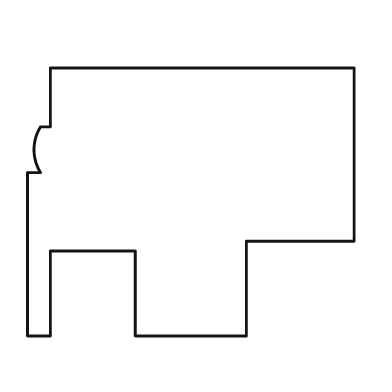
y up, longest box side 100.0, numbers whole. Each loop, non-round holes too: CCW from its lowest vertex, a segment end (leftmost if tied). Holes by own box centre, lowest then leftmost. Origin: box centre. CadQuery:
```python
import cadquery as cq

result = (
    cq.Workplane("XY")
    .moveTo(-50.0, -41.0)
    .lineTo(-43.0, -41.0)
    .lineTo(-43.0, -15.0)
    .lineTo(-17.0, -15.0)
    .lineTo(-17.0, -41.0)
    .lineTo(17.0, -41.0)
    .lineTo(17.0, -12.0)
    .lineTo(50.0, -12.0)
    .lineTo(50.0, 41.0)
    .lineTo(-43.0, 41.0)
    .lineTo(-43.0, 23.0)
    .lineTo(-46.0, 23.0)
    .threePointArc((-48.0, 16.0), (-46.0, 9.0))
    .lineTo(-50.0, 9.0)
    .close()
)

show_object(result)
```